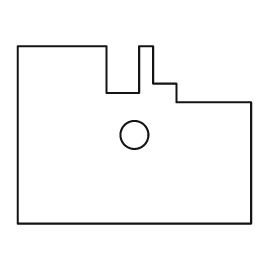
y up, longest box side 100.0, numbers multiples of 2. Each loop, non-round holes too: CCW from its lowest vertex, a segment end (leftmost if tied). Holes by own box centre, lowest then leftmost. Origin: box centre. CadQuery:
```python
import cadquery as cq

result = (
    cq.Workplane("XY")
    .moveTo(-50.0, -38.0)
    .lineTo(50.0, -38.0)
    .lineTo(50.0, 14.0)
    .lineTo(18.0, 14.0)
    .lineTo(18.0, 22.0)
    .lineTo(8.0, 22.0)
    .lineTo(8.0, 38.0)
    .lineTo(2.0, 38.0)
    .lineTo(2.0, 18.0)
    .lineTo(-12.0, 18.0)
    .lineTo(-12.0, 38.0)
    .lineTo(-50.0, 38.0)
    .close()
    .moveTo(0.0, 0.0)
    .circle(6.0)
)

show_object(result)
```